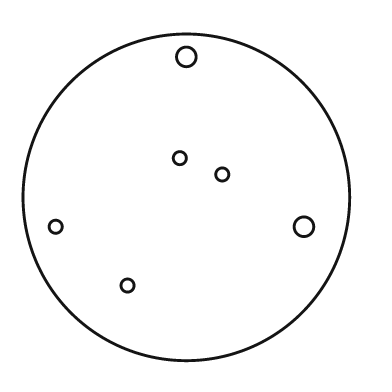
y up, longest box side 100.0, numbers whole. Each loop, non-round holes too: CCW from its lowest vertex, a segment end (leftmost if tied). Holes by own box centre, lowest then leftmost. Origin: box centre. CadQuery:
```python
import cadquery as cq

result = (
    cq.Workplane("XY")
    .moveTo(0.0, 0.0)
    .circle(50.0)
    .moveTo(-18.0, -27.0)
    .circle(2.0)
    .moveTo(-40.0, -9.0)
    .circle(2.0)
    .moveTo(36.0, -9.0)
    .circle(3.0)
    .moveTo(11.0, 7.0)
    .circle(2.0)
    .moveTo(-2.0, 12.0)
    .circle(2.0)
    .moveTo(0.0, 43.0)
    .circle(3.0)
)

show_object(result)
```